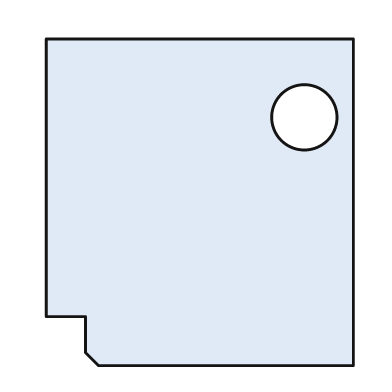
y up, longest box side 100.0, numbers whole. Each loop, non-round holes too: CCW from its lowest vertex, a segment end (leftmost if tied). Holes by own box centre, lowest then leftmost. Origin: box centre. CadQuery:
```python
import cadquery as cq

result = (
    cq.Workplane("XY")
    .moveTo(-31.0, -50.0)
    .lineTo(47.0, -50.0)
    .lineTo(47.0, 50.0)
    .lineTo(-47.0, 50.0)
    .lineTo(-47.0, -35.0)
    .lineTo(-35.0, -35.0)
    .lineTo(-35.0, -46.0)
    .close()
    .moveTo(32.0, 26.0)
    .circle(10.0)
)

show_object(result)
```